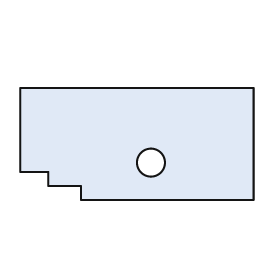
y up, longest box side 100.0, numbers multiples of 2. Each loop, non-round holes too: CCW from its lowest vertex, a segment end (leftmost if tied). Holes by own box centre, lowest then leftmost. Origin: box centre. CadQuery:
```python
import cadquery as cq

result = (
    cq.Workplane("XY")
    .moveTo(-24.0, -24.0)
    .lineTo(50.0, -24.0)
    .lineTo(50.0, 24.0)
    .lineTo(-50.0, 24.0)
    .lineTo(-50.0, -12.0)
    .lineTo(-38.0, -12.0)
    .lineTo(-38.0, -18.0)
    .lineTo(-24.0, -18.0)
    .close()
    .moveTo(6.0, -8.0)
    .circle(6.0)
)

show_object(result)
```